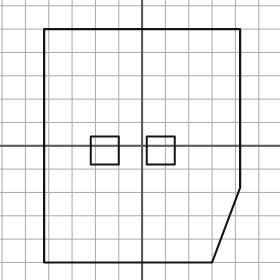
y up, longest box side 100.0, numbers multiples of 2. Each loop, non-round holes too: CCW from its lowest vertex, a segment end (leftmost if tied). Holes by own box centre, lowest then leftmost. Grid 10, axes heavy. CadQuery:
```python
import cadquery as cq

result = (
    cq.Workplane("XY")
    .moveTo(-42.0, -50.0)
    .lineTo(30.0, -50.0)
    .lineTo(42.0, -18.0)
    .lineTo(42.0, 50.0)
    .lineTo(-42.0, 50.0)
    .close()
    .moveTo(-22.0, -8.0)
    .lineTo(-10.0, -8.0)
    .lineTo(-10.0, 4.0)
    .lineTo(-22.0, 4.0)
    .close()
    .moveTo(2.0, -8.0)
    .lineTo(14.0, -8.0)
    .lineTo(14.0, 4.0)
    .lineTo(2.0, 4.0)
    .close()
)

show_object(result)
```